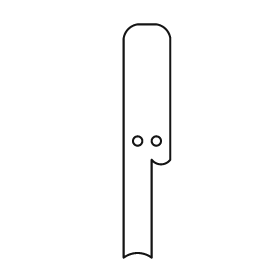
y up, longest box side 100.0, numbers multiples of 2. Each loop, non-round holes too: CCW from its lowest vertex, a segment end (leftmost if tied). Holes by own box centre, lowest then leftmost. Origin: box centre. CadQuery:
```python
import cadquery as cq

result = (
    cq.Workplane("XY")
    .moveTo(-10.0, -50.0)
    .threePointArc((-4.0, -48.0), (2.0, -50.0))
    .lineTo(2.0, -8.0)
    .threePointArc((6.0, -10.0), (10.0, -8.0))
    .lineTo(10.0, 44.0)
    .threePointArc((8.0, 48.0), (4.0, 50.0))
    .lineTo(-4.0, 50.0)
    .threePointArc((-8.0, 48.0), (-10.0, 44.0))
    .close()
    .moveTo(-4.0, 0.0)
    .circle(2.0)
    .moveTo(4.0, 0.0)
    .circle(2.0)
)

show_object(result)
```